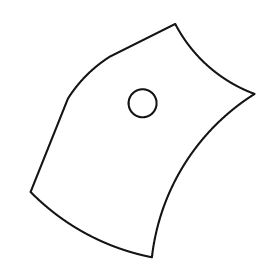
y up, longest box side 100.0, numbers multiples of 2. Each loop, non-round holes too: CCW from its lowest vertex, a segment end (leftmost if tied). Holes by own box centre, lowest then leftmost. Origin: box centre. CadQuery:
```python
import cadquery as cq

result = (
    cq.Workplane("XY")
    .moveTo(4.0, -50.0)
    .threePointArc((18.0, -10.0), (48.0, 20.0))
    .threePointArc((28.0, 32.0), (14.0, 50.0))
    .lineTo(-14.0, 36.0)
    .threePointArc((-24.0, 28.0), (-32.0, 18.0))
    .lineTo(-48.0, -22.0)
    .threePointArc((-24.0, -40.0), (4.0, -50.0))
    .close()
    .moveTo(0.0, 16.0)
    .circle(6.0)
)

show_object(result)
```